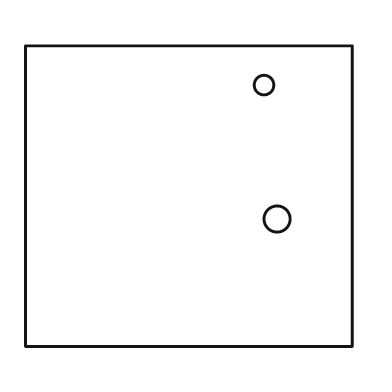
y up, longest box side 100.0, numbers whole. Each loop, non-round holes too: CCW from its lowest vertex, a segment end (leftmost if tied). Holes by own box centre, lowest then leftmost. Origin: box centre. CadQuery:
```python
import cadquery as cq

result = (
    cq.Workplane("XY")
    .moveTo(-50.0, -46.0)
    .lineTo(50.0, -46.0)
    .lineTo(50.0, 46.0)
    .lineTo(-50.0, 46.0)
    .close()
    .moveTo(27.0, -7.0)
    .circle(4.0)
    .moveTo(23.0, 34.0)
    .circle(3.0)
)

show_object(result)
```